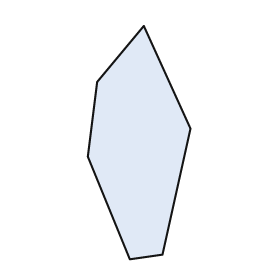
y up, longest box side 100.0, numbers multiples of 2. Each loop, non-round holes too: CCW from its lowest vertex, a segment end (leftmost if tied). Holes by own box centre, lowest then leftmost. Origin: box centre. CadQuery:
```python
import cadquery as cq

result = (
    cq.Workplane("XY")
    .moveTo(-4.0, -50.0)
    .lineTo(10.0, -48.0)
    .lineTo(22.0, 6.0)
    .lineTo(2.0, 50.0)
    .lineTo(-18.0, 26.0)
    .lineTo(-22.0, -6.0)
    .close()
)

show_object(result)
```